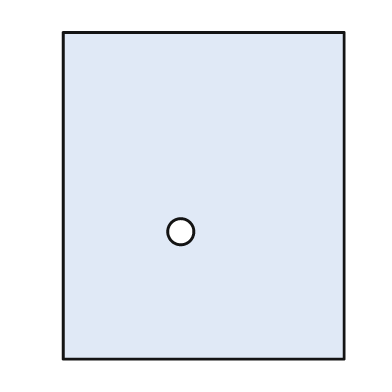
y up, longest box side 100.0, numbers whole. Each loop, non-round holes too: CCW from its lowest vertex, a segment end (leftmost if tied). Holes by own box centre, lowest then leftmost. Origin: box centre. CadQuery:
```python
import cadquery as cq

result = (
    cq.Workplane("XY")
    .moveTo(-43.0, -50.0)
    .lineTo(43.0, -50.0)
    .lineTo(43.0, 50.0)
    .lineTo(-43.0, 50.0)
    .close()
    .moveTo(-7.0, -11.0)
    .circle(4.0)
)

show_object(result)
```